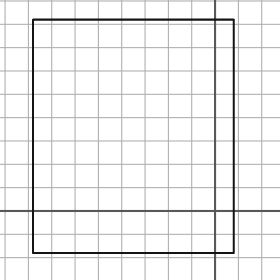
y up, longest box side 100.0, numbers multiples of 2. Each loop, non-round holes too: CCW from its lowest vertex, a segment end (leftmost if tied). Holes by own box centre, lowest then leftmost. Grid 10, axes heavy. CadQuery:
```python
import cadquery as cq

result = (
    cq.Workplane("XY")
    .moveTo(-78.0, -18.0)
    .lineTo(8.0, -18.0)
    .lineTo(8.0, 82.0)
    .lineTo(-78.0, 82.0)
    .close()
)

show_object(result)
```